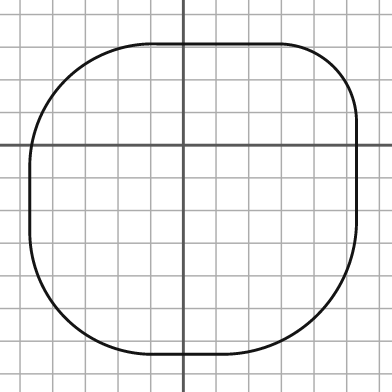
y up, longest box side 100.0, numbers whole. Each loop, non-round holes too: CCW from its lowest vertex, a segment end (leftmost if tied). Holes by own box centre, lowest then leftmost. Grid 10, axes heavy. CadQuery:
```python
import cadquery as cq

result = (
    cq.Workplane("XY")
    .moveTo(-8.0, -64.0)
    .lineTo(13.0, -64.0)
    .threePointArc((41.0, -52.0), (53.0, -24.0))
    .lineTo(53.0, 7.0)
    .threePointArc((46.0, 24.0), (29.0, 31.0))
    .lineTo(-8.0, 31.0)
    .threePointArc((-36.0, 20.0), (-47.0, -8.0))
    .lineTo(-47.0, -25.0)
    .threePointArc((-36.0, -53.0), (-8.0, -64.0))
    .close()
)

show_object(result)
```